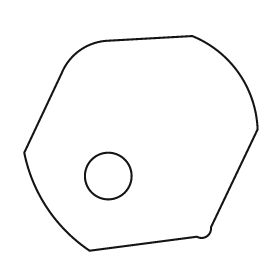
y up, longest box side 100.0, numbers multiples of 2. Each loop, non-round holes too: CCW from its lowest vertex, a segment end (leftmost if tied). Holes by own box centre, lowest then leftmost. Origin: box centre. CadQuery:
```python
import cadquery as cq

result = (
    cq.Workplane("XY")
    .moveTo(-22.0, -46.0)
    .lineTo(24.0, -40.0)
    .threePointArc((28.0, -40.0), (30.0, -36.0))
    .lineTo(50.0, 6.0)
    .threePointArc((42.0, 30.0), (22.0, 46.0))
    .lineTo(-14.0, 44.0)
    .threePointArc((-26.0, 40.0), (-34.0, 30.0))
    .lineTo(-50.0, -4.0)
    .threePointArc((-40.0, -28.0), (-22.0, -46.0))
    .close()
    .moveTo(-14.0, -14.0)
    .circle(10.0)
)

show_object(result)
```